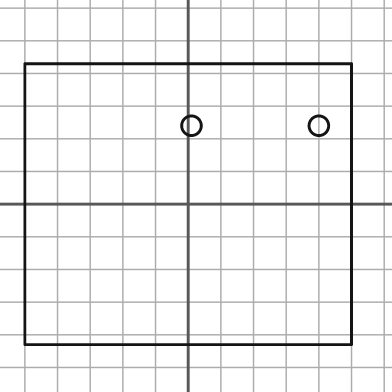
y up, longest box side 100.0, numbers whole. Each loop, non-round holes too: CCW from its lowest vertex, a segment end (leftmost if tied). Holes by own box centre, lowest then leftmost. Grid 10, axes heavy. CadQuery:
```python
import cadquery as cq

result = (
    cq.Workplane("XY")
    .moveTo(-50.0, -43.0)
    .lineTo(50.0, -43.0)
    .lineTo(50.0, 43.0)
    .lineTo(-50.0, 43.0)
    .close()
    .moveTo(1.0, 24.0)
    .circle(3.0)
    .moveTo(40.0, 24.0)
    .circle(3.0)
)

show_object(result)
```